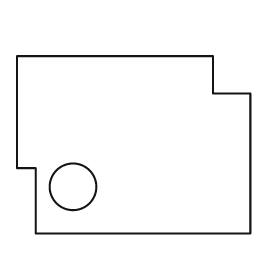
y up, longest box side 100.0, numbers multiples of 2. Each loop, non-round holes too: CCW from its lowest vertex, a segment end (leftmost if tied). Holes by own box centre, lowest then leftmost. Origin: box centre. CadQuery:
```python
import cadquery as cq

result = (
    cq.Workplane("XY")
    .moveTo(-42.0, -38.0)
    .lineTo(50.0, -38.0)
    .lineTo(50.0, 22.0)
    .lineTo(34.0, 22.0)
    .lineTo(34.0, 38.0)
    .lineTo(-50.0, 38.0)
    .lineTo(-50.0, -10.0)
    .lineTo(-42.0, -10.0)
    .close()
    .moveTo(-26.0, -18.0)
    .circle(10.0)
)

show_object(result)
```